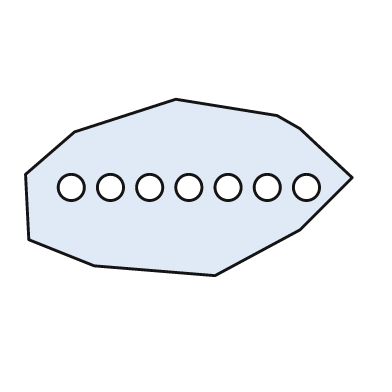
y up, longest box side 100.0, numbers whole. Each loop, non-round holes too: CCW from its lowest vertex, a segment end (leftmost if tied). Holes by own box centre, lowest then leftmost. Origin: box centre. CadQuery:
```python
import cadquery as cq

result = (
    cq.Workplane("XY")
    .moveTo(8.0, -27.0)
    .lineTo(34.0, -13.0)
    .lineTo(50.0, 3.0)
    .lineTo(34.0, 18.0)
    .lineTo(27.0, 22.0)
    .lineTo(-4.0, 27.0)
    .lineTo(-35.0, 17.0)
    .lineTo(-50.0, 4.0)
    .lineTo(-49.0, -16.0)
    .lineTo(-29.0, -24.0)
    .close()
    .moveTo(-36.0, 0.0)
    .circle(4.0)
    .moveTo(-24.0, 0.0)
    .circle(4.0)
    .moveTo(-12.0, 0.0)
    .circle(4.0)
    .moveTo(0.0, 0.0)
    .circle(4.0)
    .moveTo(12.0, 0.0)
    .circle(4.0)
    .moveTo(24.0, 0.0)
    .circle(4.0)
    .moveTo(36.0, 0.0)
    .circle(4.0)
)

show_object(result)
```